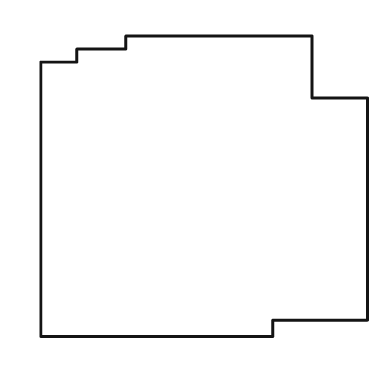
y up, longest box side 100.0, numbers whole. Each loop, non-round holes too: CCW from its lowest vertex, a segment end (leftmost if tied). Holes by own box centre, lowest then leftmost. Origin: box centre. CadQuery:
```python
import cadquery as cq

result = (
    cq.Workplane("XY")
    .moveTo(-50.0, -46.0)
    .lineTo(21.0, -46.0)
    .lineTo(21.0, -41.0)
    .lineTo(50.0, -41.0)
    .lineTo(50.0, 27.0)
    .lineTo(33.0, 27.0)
    .lineTo(33.0, 46.0)
    .lineTo(-24.0, 46.0)
    .lineTo(-24.0, 42.0)
    .lineTo(-39.0, 42.0)
    .lineTo(-39.0, 38.0)
    .lineTo(-50.0, 38.0)
    .close()
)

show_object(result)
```